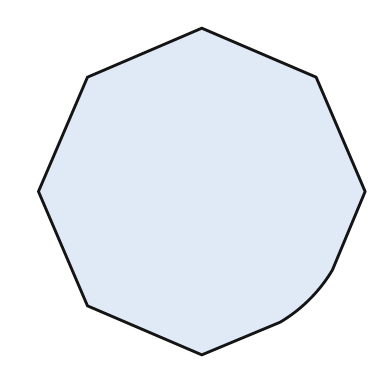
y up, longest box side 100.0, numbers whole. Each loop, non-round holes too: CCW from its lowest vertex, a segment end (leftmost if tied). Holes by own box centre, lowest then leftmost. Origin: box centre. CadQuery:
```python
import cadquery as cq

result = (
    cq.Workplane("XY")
    .moveTo(0.0, -50.0)
    .lineTo(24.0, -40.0)
    .threePointArc((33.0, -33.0), (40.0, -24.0))
    .lineTo(50.0, 0.0)
    .lineTo(35.0, 35.0)
    .lineTo(0.0, 50.0)
    .lineTo(-35.0, 35.0)
    .lineTo(-50.0, 0.0)
    .lineTo(-35.0, -35.0)
    .close()
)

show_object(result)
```